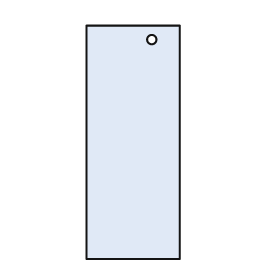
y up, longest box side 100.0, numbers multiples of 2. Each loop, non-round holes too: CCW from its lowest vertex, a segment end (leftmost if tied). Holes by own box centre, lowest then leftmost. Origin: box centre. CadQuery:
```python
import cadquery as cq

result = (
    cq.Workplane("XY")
    .moveTo(-20.0, -50.0)
    .lineTo(20.0, -50.0)
    .lineTo(20.0, 50.0)
    .lineTo(-20.0, 50.0)
    .close()
    .moveTo(8.0, 44.0)
    .circle(2.0)
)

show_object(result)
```